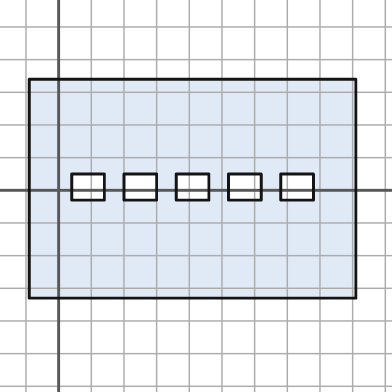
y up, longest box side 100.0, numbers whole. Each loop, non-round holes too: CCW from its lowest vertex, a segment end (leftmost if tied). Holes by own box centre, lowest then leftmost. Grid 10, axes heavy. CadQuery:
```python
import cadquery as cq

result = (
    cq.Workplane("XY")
    .moveTo(-9.0, -33.0)
    .lineTo(91.0, -33.0)
    .lineTo(91.0, 34.0)
    .lineTo(-9.0, 34.0)
    .close()
    .moveTo(4.0, -3.0)
    .lineTo(14.0, -3.0)
    .lineTo(14.0, 5.0)
    .lineTo(4.0, 5.0)
    .close()
    .moveTo(20.0, -3.0)
    .lineTo(30.0, -3.0)
    .lineTo(30.0, 5.0)
    .lineTo(20.0, 5.0)
    .close()
    .moveTo(36.0, -3.0)
    .lineTo(46.0, -3.0)
    .lineTo(46.0, 5.0)
    .lineTo(36.0, 5.0)
    .close()
    .moveTo(52.0, -3.0)
    .lineTo(62.0, -3.0)
    .lineTo(62.0, 5.0)
    .lineTo(52.0, 5.0)
    .close()
    .moveTo(68.0, -3.0)
    .lineTo(78.0, -3.0)
    .lineTo(78.0, 5.0)
    .lineTo(68.0, 5.0)
    .close()
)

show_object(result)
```